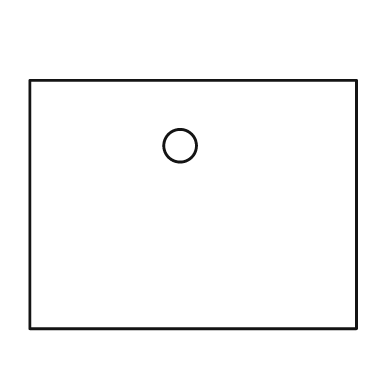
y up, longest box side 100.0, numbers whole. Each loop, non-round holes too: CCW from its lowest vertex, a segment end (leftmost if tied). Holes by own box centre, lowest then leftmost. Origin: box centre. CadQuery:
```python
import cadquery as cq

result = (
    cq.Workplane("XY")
    .moveTo(-50.0, -38.0)
    .lineTo(50.0, -38.0)
    .lineTo(50.0, 38.0)
    .lineTo(-50.0, 38.0)
    .close()
    .moveTo(-4.0, 18.0)
    .circle(5.0)
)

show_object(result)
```